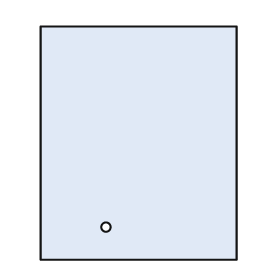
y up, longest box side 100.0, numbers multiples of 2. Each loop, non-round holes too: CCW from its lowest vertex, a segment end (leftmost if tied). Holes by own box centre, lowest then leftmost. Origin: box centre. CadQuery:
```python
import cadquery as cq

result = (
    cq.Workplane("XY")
    .moveTo(-42.0, -50.0)
    .lineTo(42.0, -50.0)
    .lineTo(42.0, 50.0)
    .lineTo(-42.0, 50.0)
    .close()
    .moveTo(-14.0, -36.0)
    .circle(2.0)
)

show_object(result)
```